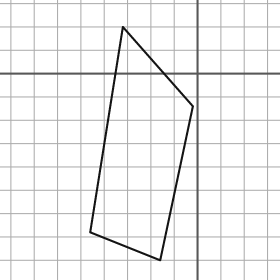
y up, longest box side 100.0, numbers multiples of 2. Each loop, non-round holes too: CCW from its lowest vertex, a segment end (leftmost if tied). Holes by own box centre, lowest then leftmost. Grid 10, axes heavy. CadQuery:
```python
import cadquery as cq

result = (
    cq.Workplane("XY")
    .moveTo(-16.0, -80.0)
    .lineTo(-2.0, -14.0)
    .lineTo(-32.0, 20.0)
    .lineTo(-46.0, -68.0)
    .close()
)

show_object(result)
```